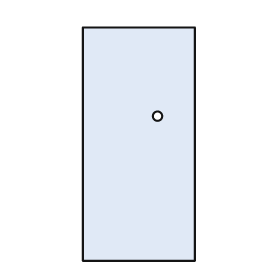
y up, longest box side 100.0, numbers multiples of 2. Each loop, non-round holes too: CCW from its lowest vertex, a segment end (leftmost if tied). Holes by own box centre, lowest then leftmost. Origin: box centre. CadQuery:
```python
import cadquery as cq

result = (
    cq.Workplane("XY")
    .moveTo(-24.0, -50.0)
    .lineTo(24.0, -50.0)
    .lineTo(24.0, 50.0)
    .lineTo(-24.0, 50.0)
    .close()
    .moveTo(8.0, 12.0)
    .circle(2.0)
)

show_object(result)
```